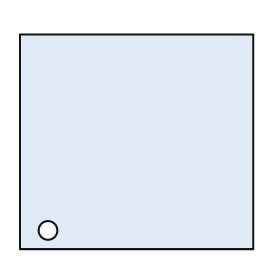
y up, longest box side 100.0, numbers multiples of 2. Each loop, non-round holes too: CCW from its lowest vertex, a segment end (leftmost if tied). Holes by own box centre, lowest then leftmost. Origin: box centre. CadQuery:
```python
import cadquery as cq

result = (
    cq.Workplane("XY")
    .moveTo(-50.0, -46.0)
    .lineTo(50.0, -46.0)
    .lineTo(50.0, 46.0)
    .lineTo(-50.0, 46.0)
    .close()
    .moveTo(-38.0, -38.0)
    .circle(4.0)
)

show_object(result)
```